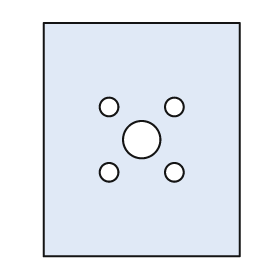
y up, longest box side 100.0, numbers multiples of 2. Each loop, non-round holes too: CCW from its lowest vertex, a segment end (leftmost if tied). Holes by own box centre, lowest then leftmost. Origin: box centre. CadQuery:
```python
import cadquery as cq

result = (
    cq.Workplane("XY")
    .moveTo(-42.0, -50.0)
    .lineTo(42.0, -50.0)
    .lineTo(42.0, 50.0)
    .lineTo(-42.0, 50.0)
    .close()
    .moveTo(-14.0, -14.0)
    .circle(4.0)
    .moveTo(14.0, -14.0)
    .circle(4.0)
    .moveTo(0.0, 0.0)
    .circle(8.0)
    .moveTo(-14.0, 14.0)
    .circle(4.0)
    .moveTo(14.0, 14.0)
    .circle(4.0)
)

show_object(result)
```